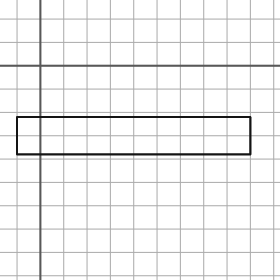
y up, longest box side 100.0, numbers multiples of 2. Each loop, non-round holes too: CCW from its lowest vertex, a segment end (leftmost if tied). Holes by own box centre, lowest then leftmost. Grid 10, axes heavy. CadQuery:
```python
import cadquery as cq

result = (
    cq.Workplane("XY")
    .moveTo(-10.0, -38.0)
    .lineTo(90.0, -38.0)
    .lineTo(90.0, -22.0)
    .lineTo(-10.0, -22.0)
    .close()
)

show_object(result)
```